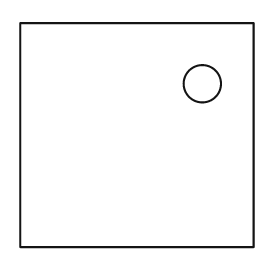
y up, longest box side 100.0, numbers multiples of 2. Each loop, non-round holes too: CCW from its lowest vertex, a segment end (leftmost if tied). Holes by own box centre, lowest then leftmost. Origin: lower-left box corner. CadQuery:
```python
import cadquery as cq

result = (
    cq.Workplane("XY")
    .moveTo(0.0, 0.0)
    .lineTo(100.0, 0.0)
    .lineTo(100.0, 96.0)
    .lineTo(0.0, 96.0)
    .close()
    .moveTo(78.0, 70.0)
    .circle(8.0)
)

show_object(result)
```